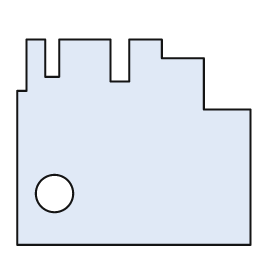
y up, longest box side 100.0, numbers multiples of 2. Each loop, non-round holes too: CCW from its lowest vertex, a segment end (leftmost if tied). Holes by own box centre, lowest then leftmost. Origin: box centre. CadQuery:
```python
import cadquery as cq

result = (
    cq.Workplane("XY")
    .moveTo(-50.0, -44.0)
    .lineTo(50.0, -44.0)
    .lineTo(50.0, 14.0)
    .lineTo(30.0, 14.0)
    .lineTo(30.0, 36.0)
    .lineTo(12.0, 36.0)
    .lineTo(12.0, 44.0)
    .lineTo(-2.0, 44.0)
    .lineTo(-2.0, 26.0)
    .lineTo(-10.0, 26.0)
    .lineTo(-10.0, 44.0)
    .lineTo(-32.0, 44.0)
    .lineTo(-32.0, 28.0)
    .lineTo(-38.0, 28.0)
    .lineTo(-38.0, 44.0)
    .lineTo(-46.0, 44.0)
    .lineTo(-46.0, 22.0)
    .lineTo(-50.0, 22.0)
    .close()
    .moveTo(-34.0, -22.0)
    .circle(8.0)
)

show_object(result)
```